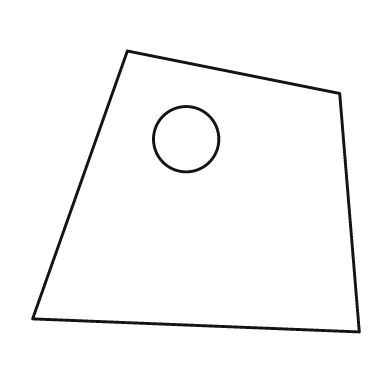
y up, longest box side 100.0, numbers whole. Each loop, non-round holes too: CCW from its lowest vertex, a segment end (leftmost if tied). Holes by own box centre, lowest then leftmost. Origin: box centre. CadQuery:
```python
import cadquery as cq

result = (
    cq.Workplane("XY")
    .moveTo(50.0, -43.0)
    .lineTo(44.0, 30.0)
    .lineTo(-21.0, 43.0)
    .lineTo(-50.0, -39.0)
    .close()
    .moveTo(-3.0, 16.0)
    .circle(10.0)
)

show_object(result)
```